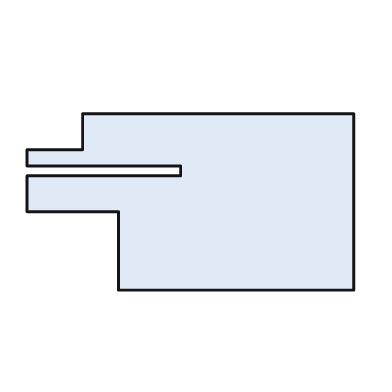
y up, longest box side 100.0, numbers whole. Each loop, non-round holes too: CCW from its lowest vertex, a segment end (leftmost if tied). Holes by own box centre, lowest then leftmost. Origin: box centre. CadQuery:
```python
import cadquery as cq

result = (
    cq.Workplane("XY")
    .moveTo(-22.0, -27.0)
    .lineTo(50.0, -27.0)
    .lineTo(50.0, 27.0)
    .lineTo(-33.0, 27.0)
    .lineTo(-33.0, 16.0)
    .lineTo(-50.0, 16.0)
    .lineTo(-50.0, 11.0)
    .lineTo(-3.0, 11.0)
    .lineTo(-3.0, 8.0)
    .lineTo(-50.0, 8.0)
    .lineTo(-50.0, -3.0)
    .lineTo(-22.0, -3.0)
    .close()
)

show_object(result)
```